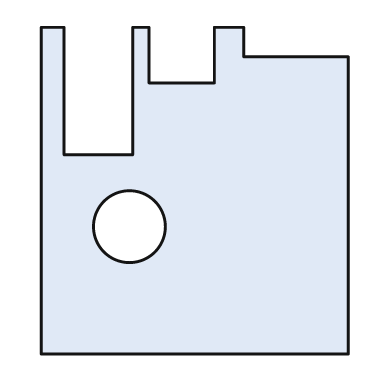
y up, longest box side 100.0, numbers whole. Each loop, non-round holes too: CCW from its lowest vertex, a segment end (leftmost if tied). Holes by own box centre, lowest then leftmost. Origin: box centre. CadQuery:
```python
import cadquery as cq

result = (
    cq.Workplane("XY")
    .moveTo(-47.0, -50.0)
    .lineTo(47.0, -50.0)
    .lineTo(47.0, 41.0)
    .lineTo(15.0, 41.0)
    .lineTo(15.0, 50.0)
    .lineTo(6.0, 50.0)
    .lineTo(6.0, 33.0)
    .lineTo(-14.0, 33.0)
    .lineTo(-14.0, 50.0)
    .lineTo(-19.0, 50.0)
    .lineTo(-19.0, 11.0)
    .lineTo(-40.0, 11.0)
    .lineTo(-40.0, 50.0)
    .lineTo(-47.0, 50.0)
    .close()
    .moveTo(-20.0, -11.0)
    .circle(11.0)
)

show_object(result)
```